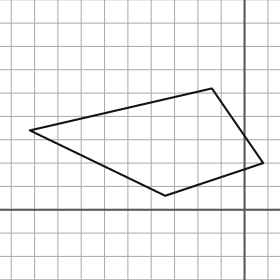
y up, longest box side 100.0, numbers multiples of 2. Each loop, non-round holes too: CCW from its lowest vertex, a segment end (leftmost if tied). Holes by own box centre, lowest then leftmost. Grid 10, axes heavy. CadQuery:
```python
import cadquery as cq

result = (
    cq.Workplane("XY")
    .moveTo(-34.0, 6.0)
    .lineTo(8.0, 20.0)
    .lineTo(-14.0, 52.0)
    .lineTo(-92.0, 34.0)
    .close()
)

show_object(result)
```